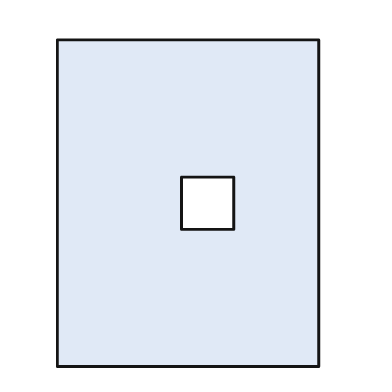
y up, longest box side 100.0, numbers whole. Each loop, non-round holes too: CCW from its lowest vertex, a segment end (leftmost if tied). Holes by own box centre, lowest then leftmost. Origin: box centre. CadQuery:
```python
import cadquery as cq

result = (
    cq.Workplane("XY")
    .moveTo(-40.0, -50.0)
    .lineTo(40.0, -50.0)
    .lineTo(40.0, 50.0)
    .lineTo(-40.0, 50.0)
    .close()
    .moveTo(-2.0, -8.0)
    .lineTo(14.0, -8.0)
    .lineTo(14.0, 8.0)
    .lineTo(-2.0, 8.0)
    .close()
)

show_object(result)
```